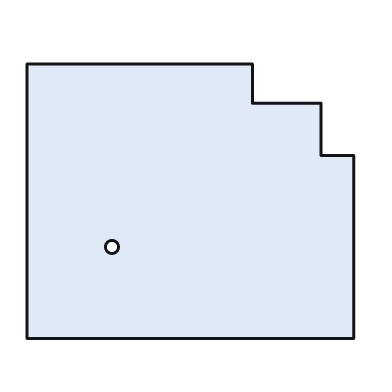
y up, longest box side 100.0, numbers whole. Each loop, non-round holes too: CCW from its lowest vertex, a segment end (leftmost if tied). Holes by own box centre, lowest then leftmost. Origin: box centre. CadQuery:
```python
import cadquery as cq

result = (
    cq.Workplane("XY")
    .moveTo(-50.0, -42.0)
    .lineTo(50.0, -42.0)
    .lineTo(50.0, 14.0)
    .lineTo(40.0, 14.0)
    .lineTo(40.0, 30.0)
    .lineTo(19.0, 30.0)
    .lineTo(19.0, 42.0)
    .lineTo(-50.0, 42.0)
    .close()
    .moveTo(-24.0, -14.0)
    .circle(2.0)
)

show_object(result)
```